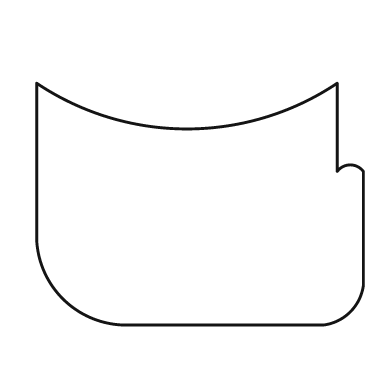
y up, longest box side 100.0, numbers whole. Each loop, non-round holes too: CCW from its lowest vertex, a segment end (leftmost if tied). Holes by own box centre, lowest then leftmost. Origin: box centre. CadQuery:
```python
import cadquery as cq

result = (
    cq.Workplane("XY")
    .moveTo(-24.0, -37.0)
    .lineTo(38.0, -37.0)
    .threePointArc((46.0, -33.0), (50.0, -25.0))
    .lineTo(50.0, 10.0)
    .threePointArc((46.0, 12.0), (42.0, 10.0))
    .lineTo(42.0, 37.0)
    .threePointArc((-4.0, 23.0), (-50.0, 37.0))
    .lineTo(-50.0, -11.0)
    .threePointArc((-42.0, -29.0), (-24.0, -37.0))
    .close()
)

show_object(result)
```